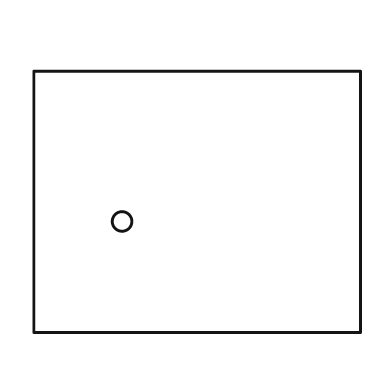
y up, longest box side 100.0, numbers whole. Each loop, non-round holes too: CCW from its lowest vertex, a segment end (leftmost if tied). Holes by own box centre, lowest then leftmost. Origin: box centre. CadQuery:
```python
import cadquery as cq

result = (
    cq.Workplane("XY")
    .moveTo(-50.0, -40.0)
    .lineTo(50.0, -40.0)
    .lineTo(50.0, 40.0)
    .lineTo(-50.0, 40.0)
    .close()
    .moveTo(-23.0, -6.0)
    .circle(3.0)
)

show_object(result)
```